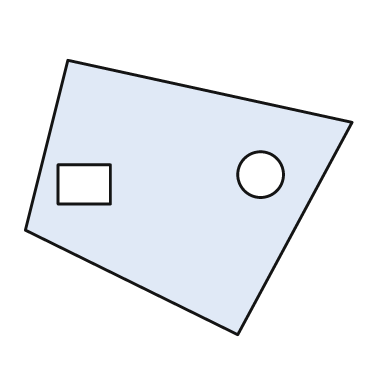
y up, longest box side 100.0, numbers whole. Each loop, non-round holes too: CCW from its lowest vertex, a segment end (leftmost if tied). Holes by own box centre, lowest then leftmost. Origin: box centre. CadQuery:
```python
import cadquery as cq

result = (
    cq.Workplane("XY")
    .moveTo(15.0, -42.0)
    .lineTo(50.0, 23.0)
    .lineTo(-37.0, 42.0)
    .lineTo(-50.0, -10.0)
    .close()
    .moveTo(-40.0, -2.0)
    .lineTo(-24.0, -2.0)
    .lineTo(-24.0, 10.0)
    .lineTo(-40.0, 10.0)
    .close()
    .moveTo(22.0, 7.0)
    .circle(7.0)
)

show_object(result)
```